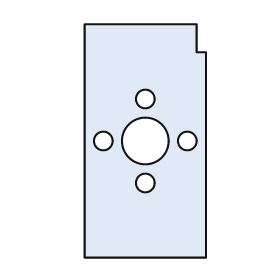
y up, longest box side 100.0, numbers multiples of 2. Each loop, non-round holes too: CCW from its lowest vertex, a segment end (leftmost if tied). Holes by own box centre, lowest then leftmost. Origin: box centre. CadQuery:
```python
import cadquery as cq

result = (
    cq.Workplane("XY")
    .moveTo(-26.0, -50.0)
    .lineTo(26.0, -50.0)
    .lineTo(26.0, 38.0)
    .lineTo(22.0, 38.0)
    .lineTo(22.0, 50.0)
    .lineTo(-26.0, 50.0)
    .close()
    .moveTo(0.0, -18.0)
    .circle(4.0)
    .moveTo(-18.0, 0.0)
    .circle(4.0)
    .moveTo(0.0, 0.0)
    .circle(10.0)
    .moveTo(18.0, 0.0)
    .circle(4.0)
    .moveTo(0.0, 18.0)
    .circle(4.0)
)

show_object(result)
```